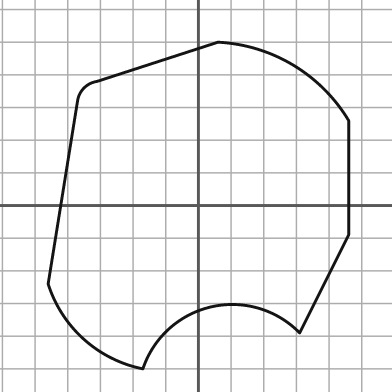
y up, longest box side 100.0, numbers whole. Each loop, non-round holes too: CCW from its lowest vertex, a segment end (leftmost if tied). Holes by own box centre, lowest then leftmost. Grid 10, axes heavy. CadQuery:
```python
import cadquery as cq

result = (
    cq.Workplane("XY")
    .moveTo(-17.0, -50.0)
    .threePointArc((4.0, -31.0), (31.0, -39.0))
    .lineTo(46.0, -9.0)
    .lineTo(46.0, 26.0)
    .threePointArc((29.0, 43.0), (6.0, 50.0))
    .lineTo(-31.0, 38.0)
    .threePointArc((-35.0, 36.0), (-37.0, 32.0))
    .lineTo(-46.0, -24.0)
    .threePointArc((-35.0, -41.0), (-17.0, -50.0))
    .close()
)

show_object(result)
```